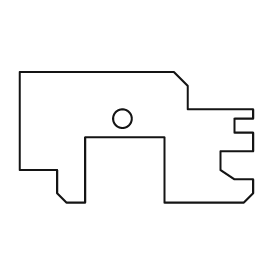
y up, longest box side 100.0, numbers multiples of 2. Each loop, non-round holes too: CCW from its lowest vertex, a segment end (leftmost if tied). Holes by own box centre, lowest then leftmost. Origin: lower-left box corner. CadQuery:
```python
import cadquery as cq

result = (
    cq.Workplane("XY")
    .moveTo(20.0, 0.0)
    .lineTo(28.0, 0.0)
    .lineTo(28.0, 28.0)
    .lineTo(62.0, 28.0)
    .lineTo(62.0, 0.0)
    .lineTo(96.0, 0.0)
    .lineTo(100.0, 4.0)
    .lineTo(100.0, 10.0)
    .lineTo(92.0, 10.0)
    .lineTo(86.0, 14.0)
    .lineTo(86.0, 22.0)
    .lineTo(100.0, 22.0)
    .lineTo(100.0, 30.0)
    .lineTo(92.0, 30.0)
    .lineTo(92.0, 36.0)
    .lineTo(100.0, 36.0)
    .lineTo(100.0, 40.0)
    .lineTo(72.0, 40.0)
    .lineTo(72.0, 50.0)
    .lineTo(66.0, 56.0)
    .lineTo(0.0, 56.0)
    .lineTo(0.0, 14.0)
    .lineTo(16.0, 14.0)
    .lineTo(16.0, 4.0)
    .close()
    .moveTo(44.0, 36.0)
    .circle(4.0)
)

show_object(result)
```